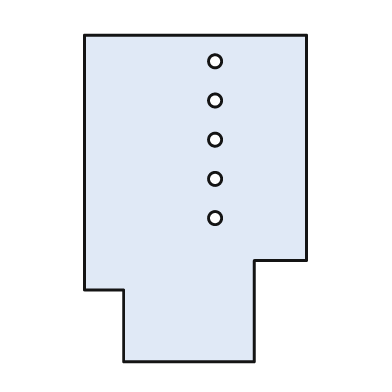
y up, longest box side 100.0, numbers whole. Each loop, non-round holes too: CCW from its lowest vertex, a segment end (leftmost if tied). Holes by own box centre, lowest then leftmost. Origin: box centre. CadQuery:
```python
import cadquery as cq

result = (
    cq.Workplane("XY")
    .moveTo(-22.0, -50.0)
    .lineTo(18.0, -50.0)
    .lineTo(18.0, -19.0)
    .lineTo(34.0, -19.0)
    .lineTo(34.0, 50.0)
    .lineTo(-34.0, 50.0)
    .lineTo(-34.0, -28.0)
    .lineTo(-22.0, -28.0)
    .close()
    .moveTo(6.0, -6.0)
    .circle(2.0)
    .moveTo(6.0, 6.0)
    .circle(2.0)
    .moveTo(6.0, 18.0)
    .circle(2.0)
    .moveTo(6.0, 30.0)
    .circle(2.0)
    .moveTo(6.0, 42.0)
    .circle(2.0)
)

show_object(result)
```